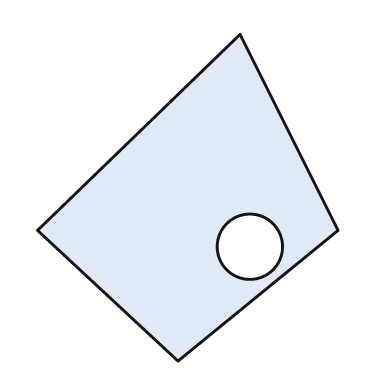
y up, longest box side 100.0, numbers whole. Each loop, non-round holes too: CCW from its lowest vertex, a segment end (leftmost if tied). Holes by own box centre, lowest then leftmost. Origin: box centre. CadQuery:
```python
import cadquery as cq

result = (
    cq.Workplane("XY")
    .moveTo(-3.0, -50.0)
    .lineTo(46.0, -10.0)
    .lineTo(16.0, 50.0)
    .lineTo(-46.0, -10.0)
    .close()
    .moveTo(19.0, -15.0)
    .circle(10.0)
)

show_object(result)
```